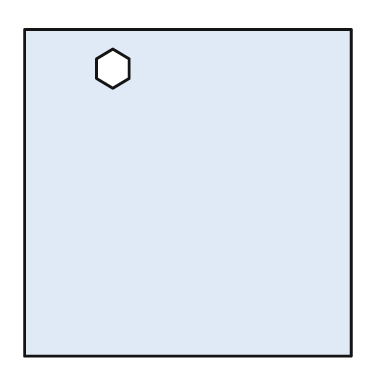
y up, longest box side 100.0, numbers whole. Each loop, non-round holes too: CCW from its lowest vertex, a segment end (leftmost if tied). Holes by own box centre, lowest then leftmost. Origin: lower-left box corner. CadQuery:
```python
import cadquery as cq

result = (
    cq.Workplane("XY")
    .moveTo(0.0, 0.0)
    .lineTo(100.0, 0.0)
    .lineTo(100.0, 100.0)
    .lineTo(0.0, 100.0)
    .close()
    .moveTo(27.0, 82.0)
    .lineTo(32.0, 85.0)
    .lineTo(32.0, 91.0)
    .lineTo(27.0, 94.0)
    .lineTo(22.0, 91.0)
    .lineTo(22.0, 85.0)
    .close()
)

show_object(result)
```